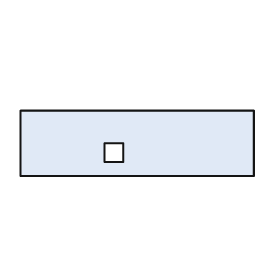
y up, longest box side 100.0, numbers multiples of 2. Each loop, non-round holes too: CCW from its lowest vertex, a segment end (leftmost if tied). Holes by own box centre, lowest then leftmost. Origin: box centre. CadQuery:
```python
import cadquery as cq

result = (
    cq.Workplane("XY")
    .moveTo(-50.0, -14.0)
    .lineTo(50.0, -14.0)
    .lineTo(50.0, 14.0)
    .lineTo(-50.0, 14.0)
    .close()
    .moveTo(-14.0, -8.0)
    .lineTo(-6.0, -8.0)
    .lineTo(-6.0, 0.0)
    .lineTo(-14.0, 0.0)
    .close()
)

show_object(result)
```